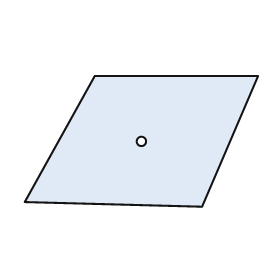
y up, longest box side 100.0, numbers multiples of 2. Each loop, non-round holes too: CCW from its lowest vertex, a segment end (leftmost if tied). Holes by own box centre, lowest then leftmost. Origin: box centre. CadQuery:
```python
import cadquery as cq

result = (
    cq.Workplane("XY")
    .moveTo(26.0, -28.0)
    .lineTo(50.0, 28.0)
    .lineTo(-20.0, 28.0)
    .lineTo(-50.0, -26.0)
    .close()
    .moveTo(0.0, 0.0)
    .circle(2.0)
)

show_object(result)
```